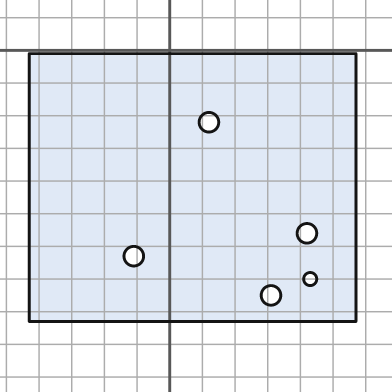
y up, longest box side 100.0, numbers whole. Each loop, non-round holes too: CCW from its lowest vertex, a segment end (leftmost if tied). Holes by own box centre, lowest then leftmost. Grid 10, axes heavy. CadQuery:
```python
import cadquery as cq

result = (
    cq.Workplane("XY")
    .moveTo(-43.0, -83.0)
    .lineTo(57.0, -83.0)
    .lineTo(57.0, -1.0)
    .lineTo(-43.0, -1.0)
    .close()
    .moveTo(31.0, -75.0)
    .circle(3.0)
    .moveTo(43.0, -70.0)
    .circle(2.0)
    .moveTo(-11.0, -63.0)
    .circle(3.0)
    .moveTo(42.0, -56.0)
    .circle(3.0)
    .moveTo(12.0, -22.0)
    .circle(3.0)
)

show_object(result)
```